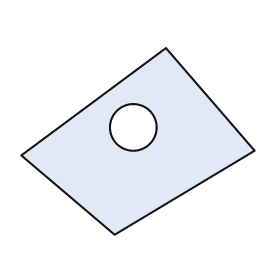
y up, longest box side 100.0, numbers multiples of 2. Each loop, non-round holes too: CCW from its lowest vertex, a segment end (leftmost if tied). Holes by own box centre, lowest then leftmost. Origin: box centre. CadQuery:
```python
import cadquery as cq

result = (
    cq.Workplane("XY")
    .moveTo(-10.0, -40.0)
    .lineTo(50.0, -4.0)
    .lineTo(12.0, 40.0)
    .lineTo(-50.0, -6.0)
    .close()
    .moveTo(-2.0, 6.0)
    .circle(10.0)
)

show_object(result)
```